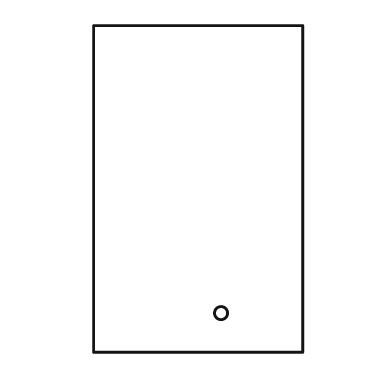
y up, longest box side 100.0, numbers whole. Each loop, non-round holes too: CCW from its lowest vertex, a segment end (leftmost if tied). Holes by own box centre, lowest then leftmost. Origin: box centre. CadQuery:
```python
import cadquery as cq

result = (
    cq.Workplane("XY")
    .moveTo(-32.0, -50.0)
    .lineTo(32.0, -50.0)
    .lineTo(32.0, 50.0)
    .lineTo(-32.0, 50.0)
    .close()
    .moveTo(7.0, -38.0)
    .circle(2.0)
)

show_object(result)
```